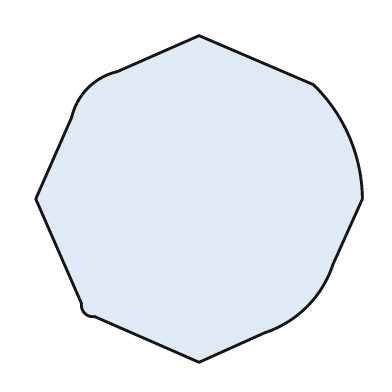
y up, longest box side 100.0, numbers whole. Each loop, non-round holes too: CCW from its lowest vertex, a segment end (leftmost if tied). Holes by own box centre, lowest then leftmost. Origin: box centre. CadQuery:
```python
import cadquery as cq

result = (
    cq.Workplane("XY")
    .moveTo(0.0, -50.0)
    .lineTo(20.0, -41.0)
    .threePointArc((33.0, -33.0), (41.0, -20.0))
    .lineTo(50.0, 0.0)
    .threePointArc((46.0, 19.0), (35.0, 35.0))
    .lineTo(0.0, 50.0)
    .lineTo(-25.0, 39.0)
    .threePointArc((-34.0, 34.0), (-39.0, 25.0))
    .lineTo(-50.0, 0.0)
    .lineTo(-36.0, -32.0)
    .threePointArc((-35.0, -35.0), (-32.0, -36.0))
    .close()
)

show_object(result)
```